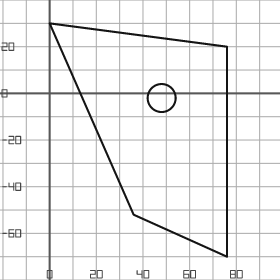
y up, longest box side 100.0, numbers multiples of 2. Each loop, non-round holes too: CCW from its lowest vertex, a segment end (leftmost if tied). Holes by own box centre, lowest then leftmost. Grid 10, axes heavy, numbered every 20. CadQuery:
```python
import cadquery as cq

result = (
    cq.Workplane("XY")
    .moveTo(76.0, -70.0)
    .lineTo(76.0, 20.0)
    .lineTo(0.0, 30.0)
    .lineTo(36.0, -52.0)
    .close()
    .moveTo(48.0, -2.0)
    .circle(6.0)
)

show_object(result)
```